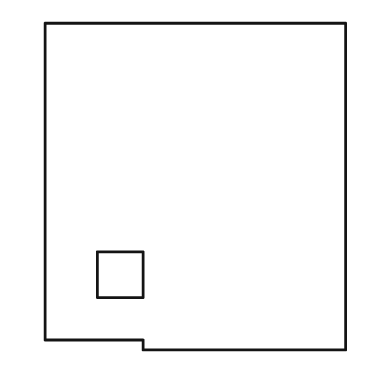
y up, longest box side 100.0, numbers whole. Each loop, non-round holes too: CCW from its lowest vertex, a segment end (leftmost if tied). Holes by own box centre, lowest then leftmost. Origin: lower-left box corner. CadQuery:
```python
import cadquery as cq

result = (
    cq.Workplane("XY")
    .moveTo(30.0, 0.0)
    .lineTo(92.0, 0.0)
    .lineTo(92.0, 100.0)
    .lineTo(0.0, 100.0)
    .lineTo(0.0, 3.0)
    .lineTo(30.0, 3.0)
    .close()
    .moveTo(16.0, 16.0)
    .lineTo(30.0, 16.0)
    .lineTo(30.0, 30.0)
    .lineTo(16.0, 30.0)
    .close()
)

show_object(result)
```